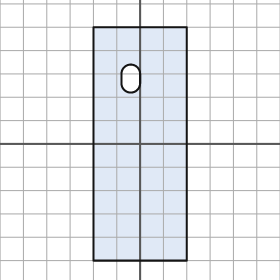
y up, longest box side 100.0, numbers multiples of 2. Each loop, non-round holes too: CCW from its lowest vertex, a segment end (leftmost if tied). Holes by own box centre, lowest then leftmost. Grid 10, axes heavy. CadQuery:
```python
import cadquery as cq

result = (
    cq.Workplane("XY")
    .moveTo(-20.0, -50.0)
    .lineTo(20.0, -50.0)
    .lineTo(20.0, 50.0)
    .lineTo(-20.0, 50.0)
    .close()
    .moveTo(-8.0, 26.0)
    .threePointArc((-4.0, 22.0), (0.0, 26.0))
    .lineTo(0.0, 30.0)
    .threePointArc((-4.0, 34.0), (-8.0, 30.0))
    .close()
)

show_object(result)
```